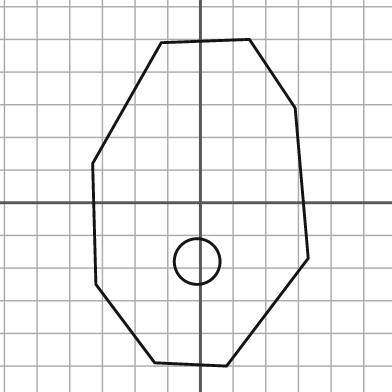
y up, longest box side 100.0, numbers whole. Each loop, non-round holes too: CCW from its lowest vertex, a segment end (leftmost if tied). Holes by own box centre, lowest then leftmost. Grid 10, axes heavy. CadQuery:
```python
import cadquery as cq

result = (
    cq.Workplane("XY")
    .moveTo(8.0, -50.0)
    .lineTo(33.0, -17.0)
    .lineTo(29.0, 29.0)
    .lineTo(15.0, 50.0)
    .lineTo(-12.0, 49.0)
    .lineTo(-33.0, 12.0)
    .lineTo(-32.0, -25.0)
    .lineTo(-14.0, -49.0)
    .close()
    .moveTo(-1.0, -18.0)
    .circle(7.0)
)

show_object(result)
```